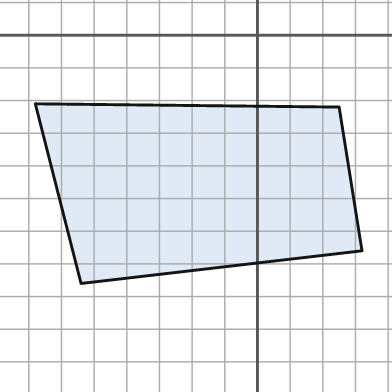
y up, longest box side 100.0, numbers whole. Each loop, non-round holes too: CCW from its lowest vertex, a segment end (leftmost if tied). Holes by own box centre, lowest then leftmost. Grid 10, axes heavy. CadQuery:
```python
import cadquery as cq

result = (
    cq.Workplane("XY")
    .moveTo(-54.0, -76.0)
    .lineTo(32.0, -66.0)
    .lineTo(25.0, -22.0)
    .lineTo(-68.0, -21.0)
    .close()
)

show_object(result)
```